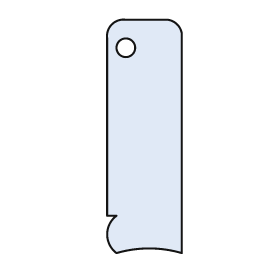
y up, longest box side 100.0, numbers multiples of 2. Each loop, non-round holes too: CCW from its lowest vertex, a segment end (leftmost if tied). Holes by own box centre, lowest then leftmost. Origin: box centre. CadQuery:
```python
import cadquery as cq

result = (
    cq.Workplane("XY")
    .moveTo(-12.0, -50.0)
    .threePointArc((2.0, -48.0), (16.0, -50.0))
    .lineTo(16.0, 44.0)
    .threePointArc((14.0, 48.0), (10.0, 50.0))
    .lineTo(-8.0, 50.0)
    .threePointArc((-14.0, 48.0), (-16.0, 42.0))
    .lineTo(-16.0, -34.0)
    .lineTo(-12.0, -34.0)
    .threePointArc((-16.0, -42.0), (-12.0, -50.0))
    .close()
    .moveTo(-8.0, 38.0)
    .circle(4.0)
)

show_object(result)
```